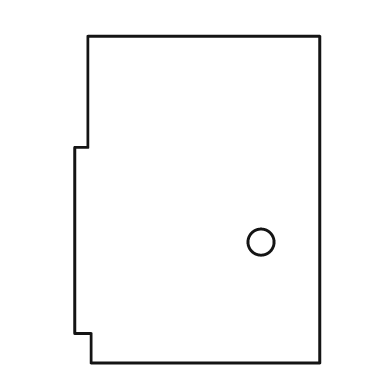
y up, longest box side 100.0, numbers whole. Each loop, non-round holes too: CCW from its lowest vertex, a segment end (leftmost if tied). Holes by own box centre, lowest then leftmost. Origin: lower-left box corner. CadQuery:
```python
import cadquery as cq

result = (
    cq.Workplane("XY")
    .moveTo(5.0, 0.0)
    .lineTo(75.0, 0.0)
    .lineTo(75.0, 100.0)
    .lineTo(4.0, 100.0)
    .lineTo(4.0, 66.0)
    .lineTo(0.0, 66.0)
    .lineTo(0.0, 9.0)
    .lineTo(5.0, 9.0)
    .close()
    .moveTo(57.0, 37.0)
    .circle(4.0)
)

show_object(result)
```